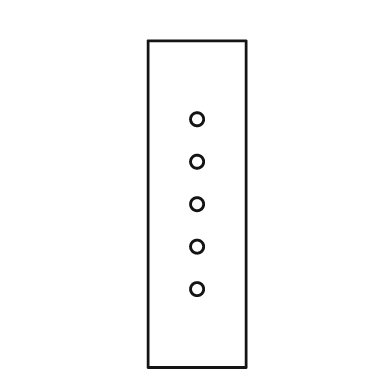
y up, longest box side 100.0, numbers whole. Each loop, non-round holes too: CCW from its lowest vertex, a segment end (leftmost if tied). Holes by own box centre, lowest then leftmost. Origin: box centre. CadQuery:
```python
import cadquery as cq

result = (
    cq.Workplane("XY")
    .moveTo(-15.0, -50.0)
    .lineTo(15.0, -50.0)
    .lineTo(15.0, 50.0)
    .lineTo(-15.0, 50.0)
    .close()
    .moveTo(0.0, -26.0)
    .circle(2.0)
    .moveTo(0.0, -13.0)
    .circle(2.0)
    .moveTo(0.0, 0.0)
    .circle(2.0)
    .moveTo(0.0, 13.0)
    .circle(2.0)
    .moveTo(0.0, 26.0)
    .circle(2.0)
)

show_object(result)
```